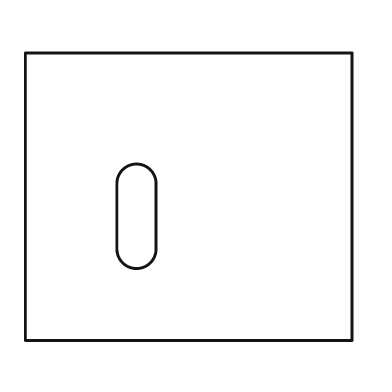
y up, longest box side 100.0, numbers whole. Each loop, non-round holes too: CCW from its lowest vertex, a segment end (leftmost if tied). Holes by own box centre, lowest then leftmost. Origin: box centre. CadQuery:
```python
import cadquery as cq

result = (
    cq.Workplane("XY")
    .moveTo(-50.0, -44.0)
    .lineTo(50.0, -44.0)
    .lineTo(50.0, 44.0)
    .lineTo(-50.0, 44.0)
    .close()
    .moveTo(-22.0, -16.0)
    .threePointArc((-16.0, -22.0), (-10.0, -16.0))
    .lineTo(-10.0, 4.0)
    .threePointArc((-16.0, 10.0), (-22.0, 4.0))
    .close()
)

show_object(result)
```